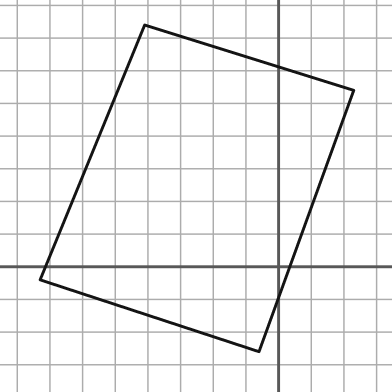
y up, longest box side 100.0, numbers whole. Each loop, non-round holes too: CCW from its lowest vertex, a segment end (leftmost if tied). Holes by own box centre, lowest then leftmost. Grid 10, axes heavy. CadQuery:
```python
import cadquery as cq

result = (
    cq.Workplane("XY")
    .moveTo(-6.0, -26.0)
    .lineTo(23.0, 54.0)
    .lineTo(-41.0, 74.0)
    .lineTo(-73.0, -4.0)
    .close()
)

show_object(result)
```